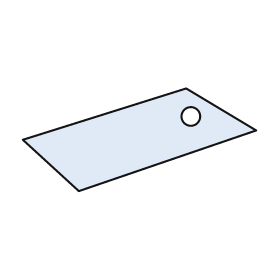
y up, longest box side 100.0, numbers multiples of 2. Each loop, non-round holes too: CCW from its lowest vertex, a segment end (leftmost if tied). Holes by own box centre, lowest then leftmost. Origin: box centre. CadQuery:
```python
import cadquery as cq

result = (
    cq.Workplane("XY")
    .moveTo(-26.0, -22.0)
    .lineTo(50.0, 4.0)
    .lineTo(20.0, 22.0)
    .lineTo(-50.0, 0.0)
    .close()
    .moveTo(22.0, 10.0)
    .circle(4.0)
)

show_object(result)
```